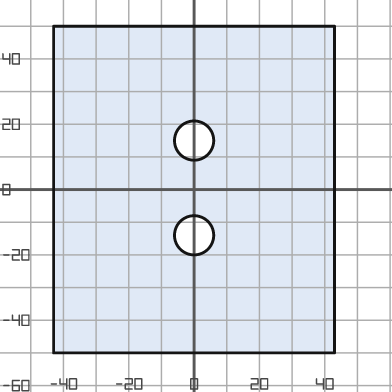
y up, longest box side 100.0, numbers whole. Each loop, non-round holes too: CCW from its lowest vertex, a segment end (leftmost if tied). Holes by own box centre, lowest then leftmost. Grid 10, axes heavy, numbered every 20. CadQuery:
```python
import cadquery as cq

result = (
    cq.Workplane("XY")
    .moveTo(-43.0, -50.0)
    .lineTo(43.0, -50.0)
    .lineTo(43.0, 50.0)
    .lineTo(-43.0, 50.0)
    .close()
    .moveTo(0.0, -14.0)
    .circle(6.0)
    .moveTo(0.0, 15.0)
    .circle(6.0)
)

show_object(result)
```